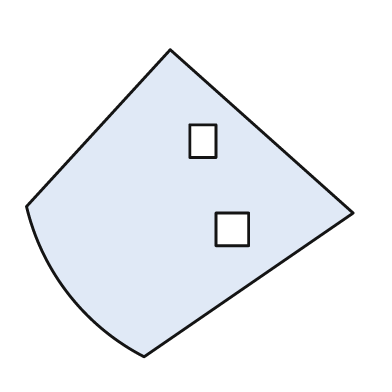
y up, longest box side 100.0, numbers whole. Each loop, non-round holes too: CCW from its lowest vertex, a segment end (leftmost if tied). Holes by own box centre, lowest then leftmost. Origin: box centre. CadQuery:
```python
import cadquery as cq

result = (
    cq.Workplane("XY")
    .moveTo(-14.0, -47.0)
    .lineTo(50.0, -3.0)
    .lineTo(-6.0, 47.0)
    .lineTo(-50.0, -1.0)
    .threePointArc((-37.0, -28.0), (-14.0, -47.0))
    .close()
    .moveTo(8.0, -13.0)
    .lineTo(18.0, -13.0)
    .lineTo(18.0, -3.0)
    .lineTo(8.0, -3.0)
    .close()
    .moveTo(0.0, 14.0)
    .lineTo(8.0, 14.0)
    .lineTo(8.0, 24.0)
    .lineTo(0.0, 24.0)
    .close()
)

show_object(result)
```